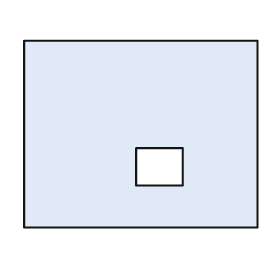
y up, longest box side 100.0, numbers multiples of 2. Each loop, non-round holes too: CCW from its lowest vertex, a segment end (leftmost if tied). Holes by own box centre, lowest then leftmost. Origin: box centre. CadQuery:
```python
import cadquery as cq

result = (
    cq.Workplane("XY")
    .moveTo(-50.0, -40.0)
    .lineTo(50.0, -40.0)
    .lineTo(50.0, 40.0)
    .lineTo(-50.0, 40.0)
    .close()
    .moveTo(-2.0, -22.0)
    .lineTo(18.0, -22.0)
    .lineTo(18.0, -6.0)
    .lineTo(-2.0, -6.0)
    .close()
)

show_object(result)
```